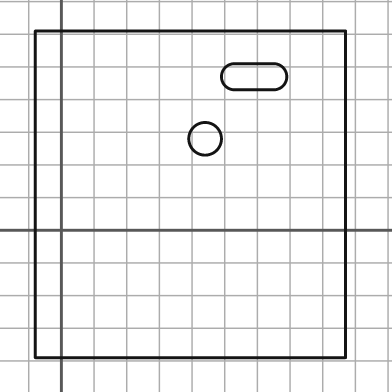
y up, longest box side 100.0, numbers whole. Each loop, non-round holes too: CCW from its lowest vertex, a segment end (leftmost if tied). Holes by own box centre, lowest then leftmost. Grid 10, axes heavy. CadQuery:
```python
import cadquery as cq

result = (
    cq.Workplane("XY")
    .moveTo(-8.0, -39.0)
    .lineTo(87.0, -39.0)
    .lineTo(87.0, 61.0)
    .lineTo(-8.0, 61.0)
    .close()
    .moveTo(44.0, 28.0)
    .circle(5.0)
    .moveTo(53.0, 43.0)
    .lineTo(65.0, 43.0)
    .threePointArc((69.0, 47.0), (65.0, 51.0))
    .lineTo(53.0, 51.0)
    .threePointArc((49.0, 47.0), (53.0, 43.0))
    .close()
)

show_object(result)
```